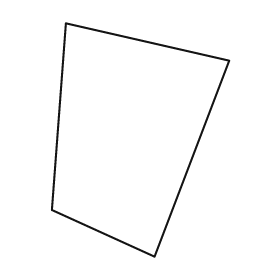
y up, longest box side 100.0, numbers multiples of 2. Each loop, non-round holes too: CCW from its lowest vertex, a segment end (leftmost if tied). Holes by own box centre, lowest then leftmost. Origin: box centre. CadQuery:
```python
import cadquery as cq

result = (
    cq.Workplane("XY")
    .moveTo(6.0, -50.0)
    .lineTo(38.0, 34.0)
    .lineTo(-32.0, 50.0)
    .lineTo(-38.0, -30.0)
    .close()
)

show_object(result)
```